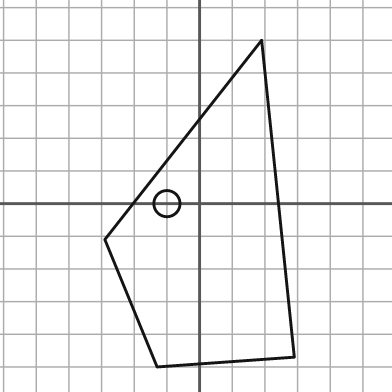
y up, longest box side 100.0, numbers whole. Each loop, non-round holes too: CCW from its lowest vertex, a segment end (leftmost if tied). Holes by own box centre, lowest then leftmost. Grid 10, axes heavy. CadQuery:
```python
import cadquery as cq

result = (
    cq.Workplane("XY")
    .moveTo(-13.0, -50.0)
    .lineTo(29.0, -47.0)
    .lineTo(19.0, 50.0)
    .lineTo(-29.0, -11.0)
    .close()
    .moveTo(-10.0, 0.0)
    .circle(4.0)
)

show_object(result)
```